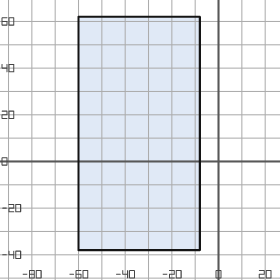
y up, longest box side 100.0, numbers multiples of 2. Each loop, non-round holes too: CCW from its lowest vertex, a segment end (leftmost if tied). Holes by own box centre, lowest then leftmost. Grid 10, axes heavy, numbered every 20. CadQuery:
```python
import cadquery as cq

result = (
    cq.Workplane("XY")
    .moveTo(-60.0, -38.0)
    .lineTo(-8.0, -38.0)
    .lineTo(-8.0, 62.0)
    .lineTo(-60.0, 62.0)
    .close()
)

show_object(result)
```